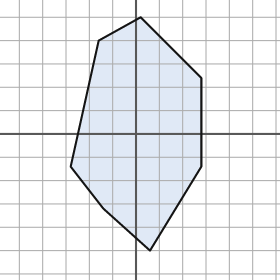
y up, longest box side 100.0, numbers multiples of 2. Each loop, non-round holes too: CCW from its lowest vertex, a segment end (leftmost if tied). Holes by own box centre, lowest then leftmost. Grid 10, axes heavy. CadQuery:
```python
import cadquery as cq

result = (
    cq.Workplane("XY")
    .moveTo(6.0, -50.0)
    .lineTo(28.0, -14.0)
    .lineTo(28.0, 24.0)
    .lineTo(2.0, 50.0)
    .lineTo(-16.0, 40.0)
    .lineTo(-28.0, -14.0)
    .lineTo(-14.0, -32.0)
    .close()
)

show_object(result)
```